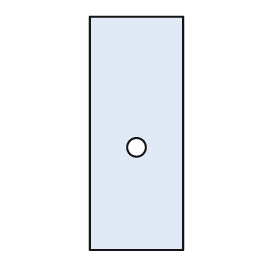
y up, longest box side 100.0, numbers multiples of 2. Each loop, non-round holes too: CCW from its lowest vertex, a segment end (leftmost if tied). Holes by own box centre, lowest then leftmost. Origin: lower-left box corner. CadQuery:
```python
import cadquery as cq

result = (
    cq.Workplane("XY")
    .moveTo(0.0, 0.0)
    .lineTo(40.0, 0.0)
    .lineTo(40.0, 100.0)
    .lineTo(0.0, 100.0)
    .close()
    .moveTo(20.0, 44.0)
    .circle(4.0)
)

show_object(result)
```